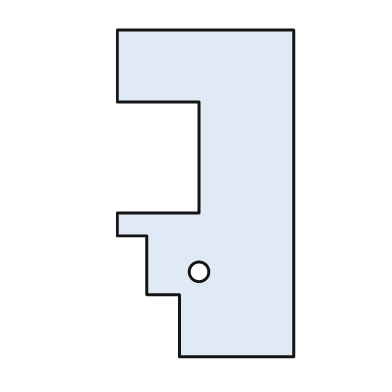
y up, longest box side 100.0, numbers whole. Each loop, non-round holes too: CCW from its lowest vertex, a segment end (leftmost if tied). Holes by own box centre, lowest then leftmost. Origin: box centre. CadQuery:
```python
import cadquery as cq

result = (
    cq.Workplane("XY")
    .moveTo(-8.0, -50.0)
    .lineTo(27.0, -50.0)
    .lineTo(27.0, 50.0)
    .lineTo(-27.0, 50.0)
    .lineTo(-27.0, 28.0)
    .lineTo(-2.0, 28.0)
    .lineTo(-2.0, -6.0)
    .lineTo(-27.0, -6.0)
    .lineTo(-27.0, -13.0)
    .lineTo(-18.0, -13.0)
    .lineTo(-18.0, -31.0)
    .lineTo(-8.0, -31.0)
    .close()
    .moveTo(-2.0, -24.0)
    .circle(3.0)
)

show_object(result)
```